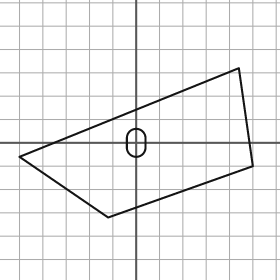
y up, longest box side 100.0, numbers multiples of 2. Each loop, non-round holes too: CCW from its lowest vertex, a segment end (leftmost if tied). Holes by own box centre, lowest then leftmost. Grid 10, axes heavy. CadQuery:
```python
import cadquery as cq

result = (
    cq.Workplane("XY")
    .moveTo(-12.0, -32.0)
    .lineTo(50.0, -10.0)
    .lineTo(44.0, 32.0)
    .lineTo(-50.0, -6.0)
    .close()
    .moveTo(-4.0, -2.0)
    .threePointArc((0.0, -6.0), (4.0, -2.0))
    .lineTo(4.0, 2.0)
    .threePointArc((0.0, 6.0), (-4.0, 2.0))
    .close()
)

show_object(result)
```